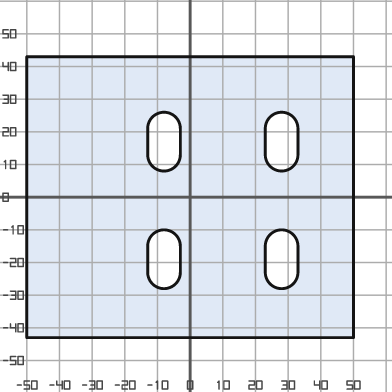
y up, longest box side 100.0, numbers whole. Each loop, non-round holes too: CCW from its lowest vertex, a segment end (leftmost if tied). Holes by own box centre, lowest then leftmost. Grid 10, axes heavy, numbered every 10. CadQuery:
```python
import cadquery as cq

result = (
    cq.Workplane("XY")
    .moveTo(-50.0, -43.0)
    .lineTo(50.0, -43.0)
    .lineTo(50.0, 43.0)
    .lineTo(-50.0, 43.0)
    .close()
    .moveTo(-13.0, -23.0)
    .threePointArc((-8.0, -28.0), (-3.0, -23.0))
    .lineTo(-3.0, -15.0)
    .threePointArc((-8.0, -10.0), (-13.0, -15.0))
    .close()
    .moveTo(23.0, -23.0)
    .threePointArc((28.0, -28.0), (33.0, -23.0))
    .lineTo(33.0, -15.0)
    .threePointArc((28.0, -10.0), (23.0, -15.0))
    .close()
    .moveTo(-13.0, 13.0)
    .threePointArc((-8.0, 8.0), (-3.0, 13.0))
    .lineTo(-3.0, 21.0)
    .threePointArc((-8.0, 26.0), (-13.0, 21.0))
    .close()
    .moveTo(23.0, 13.0)
    .threePointArc((28.0, 8.0), (33.0, 13.0))
    .lineTo(33.0, 21.0)
    .threePointArc((28.0, 26.0), (23.0, 21.0))
    .close()
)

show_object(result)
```